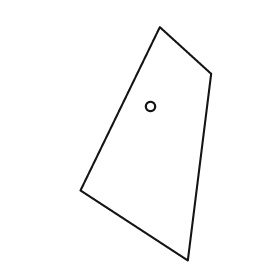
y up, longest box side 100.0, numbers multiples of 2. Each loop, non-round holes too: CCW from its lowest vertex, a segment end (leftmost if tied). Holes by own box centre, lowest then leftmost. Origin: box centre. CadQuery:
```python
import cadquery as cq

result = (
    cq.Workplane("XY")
    .moveTo(18.0, -50.0)
    .lineTo(28.0, 30.0)
    .lineTo(6.0, 50.0)
    .lineTo(-28.0, -20.0)
    .close()
    .moveTo(2.0, 16.0)
    .circle(2.0)
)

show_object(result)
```